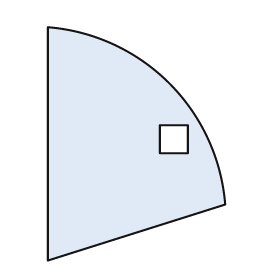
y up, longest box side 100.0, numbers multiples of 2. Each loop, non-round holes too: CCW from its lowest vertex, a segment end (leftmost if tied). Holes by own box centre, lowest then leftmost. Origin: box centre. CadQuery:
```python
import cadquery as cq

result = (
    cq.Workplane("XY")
    .moveTo(-38.0, -50.0)
    .lineTo(38.0, -26.0)
    .threePointArc((14.0, 26.0), (-38.0, 50.0))
    .close()
    .moveTo(10.0, -4.0)
    .lineTo(22.0, -4.0)
    .lineTo(22.0, 8.0)
    .lineTo(10.0, 8.0)
    .close()
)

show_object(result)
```